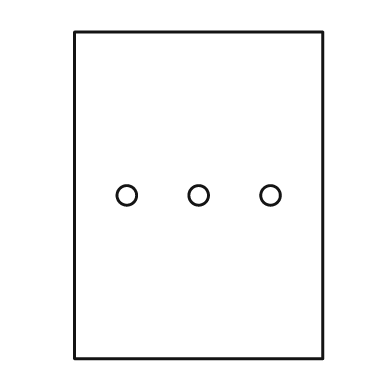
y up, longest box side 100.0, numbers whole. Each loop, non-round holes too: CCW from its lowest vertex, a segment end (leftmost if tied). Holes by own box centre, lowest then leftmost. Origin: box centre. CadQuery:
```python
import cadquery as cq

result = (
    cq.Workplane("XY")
    .moveTo(-38.0, -50.0)
    .lineTo(38.0, -50.0)
    .lineTo(38.0, 50.0)
    .lineTo(-38.0, 50.0)
    .close()
    .moveTo(-22.0, 0.0)
    .circle(3.0)
    .moveTo(0.0, 0.0)
    .circle(3.0)
    .moveTo(22.0, 0.0)
    .circle(3.0)
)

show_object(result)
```